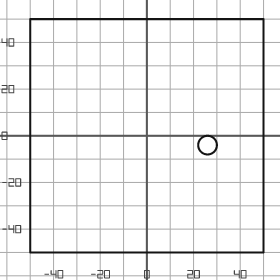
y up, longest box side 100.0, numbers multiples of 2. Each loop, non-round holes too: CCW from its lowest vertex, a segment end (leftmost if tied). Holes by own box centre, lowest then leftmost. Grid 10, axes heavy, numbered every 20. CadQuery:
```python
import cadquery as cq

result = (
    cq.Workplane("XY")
    .moveTo(-50.0, -50.0)
    .lineTo(50.0, -50.0)
    .lineTo(50.0, 50.0)
    .lineTo(-50.0, 50.0)
    .close()
    .moveTo(26.0, -4.0)
    .circle(4.0)
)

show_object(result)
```